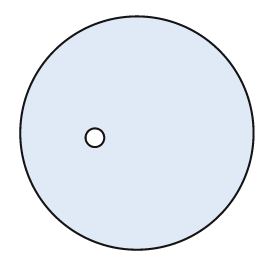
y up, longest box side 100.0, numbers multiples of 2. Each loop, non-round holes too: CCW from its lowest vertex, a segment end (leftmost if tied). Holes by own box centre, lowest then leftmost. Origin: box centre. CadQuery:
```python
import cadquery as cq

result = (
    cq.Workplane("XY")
    .moveTo(0.0, 0.0)
    .circle(50.0)
    .moveTo(-18.0, -2.0)
    .circle(4.0)
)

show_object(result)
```